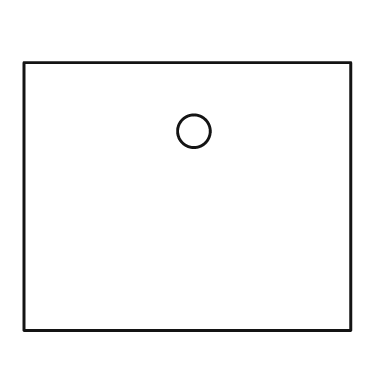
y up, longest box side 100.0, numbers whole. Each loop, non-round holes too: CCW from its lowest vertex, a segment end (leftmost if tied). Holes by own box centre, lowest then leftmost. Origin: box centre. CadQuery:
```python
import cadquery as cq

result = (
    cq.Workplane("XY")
    .moveTo(-50.0, -41.0)
    .lineTo(50.0, -41.0)
    .lineTo(50.0, 41.0)
    .lineTo(-50.0, 41.0)
    .close()
    .moveTo(2.0, 20.0)
    .circle(5.0)
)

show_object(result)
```